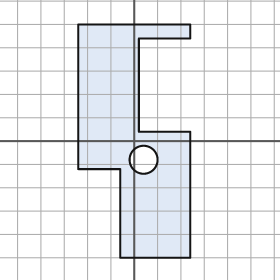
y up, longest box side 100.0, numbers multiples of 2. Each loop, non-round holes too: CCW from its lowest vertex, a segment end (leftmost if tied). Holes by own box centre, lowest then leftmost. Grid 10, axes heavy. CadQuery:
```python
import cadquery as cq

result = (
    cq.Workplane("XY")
    .moveTo(-6.0, -50.0)
    .lineTo(24.0, -50.0)
    .lineTo(24.0, 4.0)
    .lineTo(2.0, 4.0)
    .lineTo(2.0, 44.0)
    .lineTo(24.0, 44.0)
    .lineTo(24.0, 50.0)
    .lineTo(-24.0, 50.0)
    .lineTo(-24.0, -12.0)
    .lineTo(-6.0, -12.0)
    .close()
    .moveTo(4.0, -8.0)
    .circle(6.0)
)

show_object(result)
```